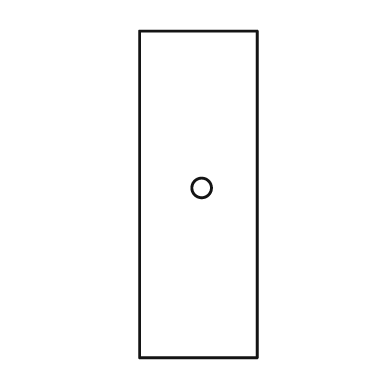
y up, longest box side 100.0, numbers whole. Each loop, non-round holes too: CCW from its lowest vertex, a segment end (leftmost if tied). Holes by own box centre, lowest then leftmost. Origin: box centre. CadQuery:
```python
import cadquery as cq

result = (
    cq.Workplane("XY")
    .moveTo(-18.0, -50.0)
    .lineTo(18.0, -50.0)
    .lineTo(18.0, 50.0)
    .lineTo(-18.0, 50.0)
    .close()
    .moveTo(1.0, 2.0)
    .circle(3.0)
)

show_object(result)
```